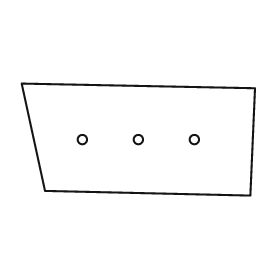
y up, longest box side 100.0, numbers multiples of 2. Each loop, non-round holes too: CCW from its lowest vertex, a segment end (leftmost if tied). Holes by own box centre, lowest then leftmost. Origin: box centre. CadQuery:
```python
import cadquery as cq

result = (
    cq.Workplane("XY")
    .moveTo(48.0, -24.0)
    .lineTo(50.0, 22.0)
    .lineTo(-50.0, 24.0)
    .lineTo(-40.0, -22.0)
    .close()
    .moveTo(-24.0, 0.0)
    .circle(2.0)
    .moveTo(0.0, 0.0)
    .circle(2.0)
    .moveTo(24.0, 0.0)
    .circle(2.0)
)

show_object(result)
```